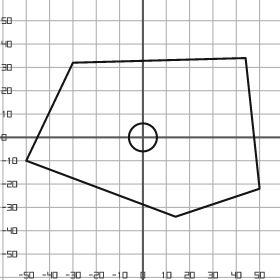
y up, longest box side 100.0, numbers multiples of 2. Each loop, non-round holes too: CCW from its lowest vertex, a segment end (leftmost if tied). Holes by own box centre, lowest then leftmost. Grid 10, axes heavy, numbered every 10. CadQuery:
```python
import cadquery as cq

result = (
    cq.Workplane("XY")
    .moveTo(14.0, -34.0)
    .lineTo(50.0, -22.0)
    .lineTo(44.0, 34.0)
    .lineTo(-30.0, 32.0)
    .lineTo(-50.0, -10.0)
    .close()
    .moveTo(0.0, 0.0)
    .circle(6.0)
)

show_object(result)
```